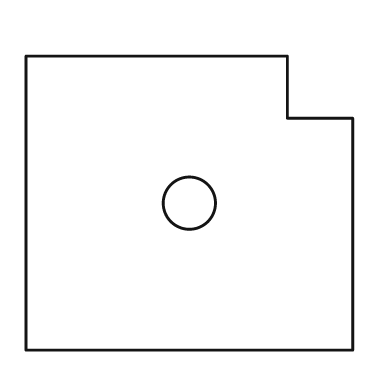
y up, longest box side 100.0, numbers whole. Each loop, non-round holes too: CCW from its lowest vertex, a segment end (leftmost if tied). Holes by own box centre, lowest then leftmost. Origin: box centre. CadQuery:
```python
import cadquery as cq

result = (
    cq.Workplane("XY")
    .moveTo(-50.0, -45.0)
    .lineTo(50.0, -45.0)
    .lineTo(50.0, 26.0)
    .lineTo(30.0, 26.0)
    .lineTo(30.0, 45.0)
    .lineTo(-50.0, 45.0)
    .close()
    .moveTo(0.0, 0.0)
    .circle(8.0)
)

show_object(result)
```